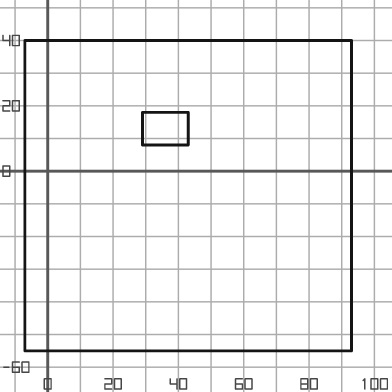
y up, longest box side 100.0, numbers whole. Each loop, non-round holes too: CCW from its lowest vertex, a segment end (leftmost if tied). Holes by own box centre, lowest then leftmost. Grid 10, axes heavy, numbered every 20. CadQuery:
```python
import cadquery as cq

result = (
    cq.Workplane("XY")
    .moveTo(-7.0, -55.0)
    .lineTo(93.0, -55.0)
    .lineTo(93.0, 40.0)
    .lineTo(-7.0, 40.0)
    .close()
    .moveTo(29.0, 8.0)
    .lineTo(43.0, 8.0)
    .lineTo(43.0, 18.0)
    .lineTo(29.0, 18.0)
    .close()
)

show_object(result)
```